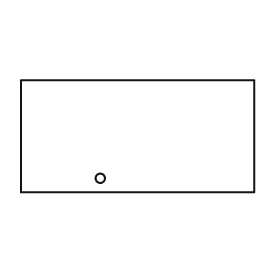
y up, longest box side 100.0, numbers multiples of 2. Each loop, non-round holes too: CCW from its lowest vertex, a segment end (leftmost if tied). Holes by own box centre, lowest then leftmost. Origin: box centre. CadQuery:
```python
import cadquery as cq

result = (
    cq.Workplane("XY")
    .moveTo(-50.0, -24.0)
    .lineTo(50.0, -24.0)
    .lineTo(50.0, 24.0)
    .lineTo(-50.0, 24.0)
    .close()
    .moveTo(-16.0, -18.0)
    .circle(2.0)
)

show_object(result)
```